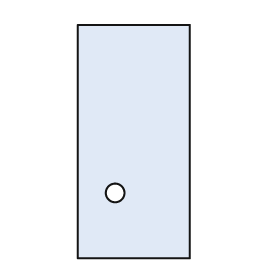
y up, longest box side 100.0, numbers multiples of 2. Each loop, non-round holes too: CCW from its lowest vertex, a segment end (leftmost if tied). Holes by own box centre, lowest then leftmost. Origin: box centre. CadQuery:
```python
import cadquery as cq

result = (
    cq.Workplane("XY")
    .moveTo(-24.0, -50.0)
    .lineTo(24.0, -50.0)
    .lineTo(24.0, 50.0)
    .lineTo(-24.0, 50.0)
    .close()
    .moveTo(-8.0, -22.0)
    .circle(4.0)
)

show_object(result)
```